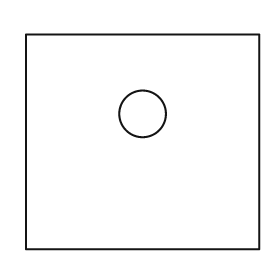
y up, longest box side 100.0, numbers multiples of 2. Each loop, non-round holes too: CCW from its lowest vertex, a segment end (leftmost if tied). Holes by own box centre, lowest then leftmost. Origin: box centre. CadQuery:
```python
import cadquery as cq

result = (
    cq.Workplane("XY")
    .moveTo(-50.0, -46.0)
    .lineTo(50.0, -46.0)
    .lineTo(50.0, 46.0)
    .lineTo(-50.0, 46.0)
    .close()
    .moveTo(0.0, 12.0)
    .circle(10.0)
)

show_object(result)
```